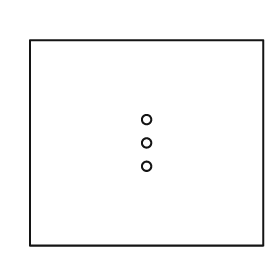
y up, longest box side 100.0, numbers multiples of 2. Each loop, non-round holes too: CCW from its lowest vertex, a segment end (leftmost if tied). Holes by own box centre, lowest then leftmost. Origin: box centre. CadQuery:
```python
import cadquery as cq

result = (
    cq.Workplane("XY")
    .moveTo(-50.0, -44.0)
    .lineTo(50.0, -44.0)
    .lineTo(50.0, 44.0)
    .lineTo(-50.0, 44.0)
    .close()
    .moveTo(0.0, -10.0)
    .circle(2.0)
    .moveTo(0.0, 0.0)
    .circle(2.0)
    .moveTo(0.0, 10.0)
    .circle(2.0)
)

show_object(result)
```